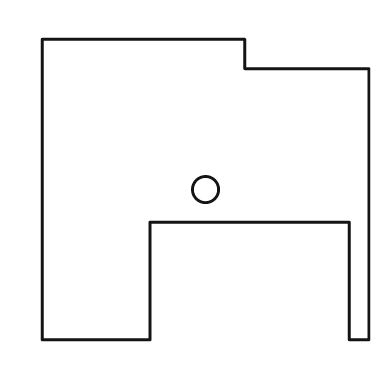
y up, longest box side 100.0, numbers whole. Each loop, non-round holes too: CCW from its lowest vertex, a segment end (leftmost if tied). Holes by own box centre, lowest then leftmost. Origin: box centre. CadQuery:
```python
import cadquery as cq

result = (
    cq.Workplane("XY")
    .moveTo(-50.0, -46.0)
    .lineTo(-17.0, -46.0)
    .lineTo(-17.0, -10.0)
    .lineTo(44.0, -10.0)
    .lineTo(44.0, -46.0)
    .lineTo(50.0, -46.0)
    .lineTo(50.0, 37.0)
    .lineTo(12.0, 37.0)
    .lineTo(12.0, 46.0)
    .lineTo(-50.0, 46.0)
    .close()
    .moveTo(0.0, 0.0)
    .circle(4.0)
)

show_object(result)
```